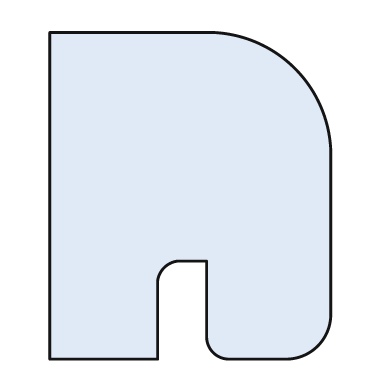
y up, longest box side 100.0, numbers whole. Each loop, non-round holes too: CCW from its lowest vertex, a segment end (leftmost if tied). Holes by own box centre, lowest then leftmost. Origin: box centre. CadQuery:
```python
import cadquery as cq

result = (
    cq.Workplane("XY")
    .moveTo(-43.0, -50.0)
    .lineTo(-10.0, -50.0)
    .lineTo(-10.0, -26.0)
    .threePointArc((-8.0, -22.0), (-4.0, -20.0))
    .lineTo(5.0, -20.0)
    .lineTo(5.0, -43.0)
    .threePointArc((7.0, -48.0), (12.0, -50.0))
    .lineTo(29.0, -50.0)
    .threePointArc((39.0, -46.0), (43.0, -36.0))
    .lineTo(43.0, 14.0)
    .threePointArc((32.0, 39.0), (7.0, 50.0))
    .lineTo(-43.0, 50.0)
    .close()
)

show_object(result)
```